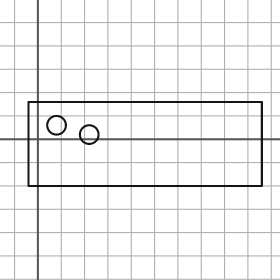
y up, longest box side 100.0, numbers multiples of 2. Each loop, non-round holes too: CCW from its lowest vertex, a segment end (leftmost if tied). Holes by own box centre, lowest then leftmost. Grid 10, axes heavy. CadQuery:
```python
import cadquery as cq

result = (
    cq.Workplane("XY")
    .moveTo(-4.0, -20.0)
    .lineTo(96.0, -20.0)
    .lineTo(96.0, 16.0)
    .lineTo(-4.0, 16.0)
    .close()
    .moveTo(22.0, 2.0)
    .circle(4.0)
    .moveTo(8.0, 6.0)
    .circle(4.0)
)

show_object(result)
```